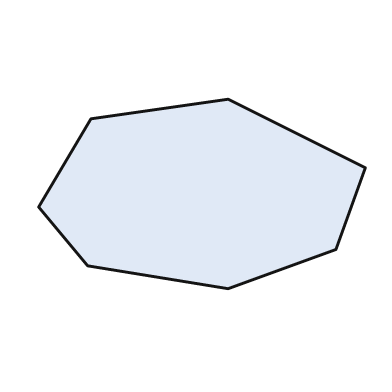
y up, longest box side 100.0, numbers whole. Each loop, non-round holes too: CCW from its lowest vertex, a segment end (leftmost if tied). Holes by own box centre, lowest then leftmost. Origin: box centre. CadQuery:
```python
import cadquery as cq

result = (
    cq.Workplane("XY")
    .moveTo(8.0, -29.0)
    .lineTo(41.0, -17.0)
    .lineTo(50.0, 8.0)
    .lineTo(8.0, 29.0)
    .lineTo(-34.0, 23.0)
    .lineTo(-50.0, -4.0)
    .lineTo(-35.0, -22.0)
    .close()
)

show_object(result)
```